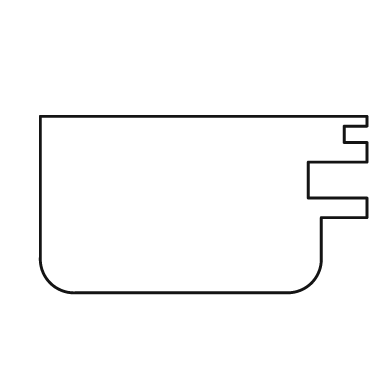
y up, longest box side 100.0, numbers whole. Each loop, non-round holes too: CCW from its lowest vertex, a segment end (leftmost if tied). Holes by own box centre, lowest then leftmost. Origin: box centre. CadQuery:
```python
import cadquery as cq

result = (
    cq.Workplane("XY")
    .moveTo(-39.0, -27.0)
    .lineTo(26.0, -27.0)
    .threePointArc((33.0, -24.0), (36.0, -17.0))
    .lineTo(36.0, -4.0)
    .lineTo(50.0, -4.0)
    .lineTo(50.0, 2.0)
    .lineTo(32.0, 2.0)
    .lineTo(32.0, 13.0)
    .lineTo(50.0, 13.0)
    .lineTo(50.0, 19.0)
    .lineTo(43.0, 19.0)
    .lineTo(43.0, 24.0)
    .lineTo(50.0, 24.0)
    .lineTo(50.0, 27.0)
    .lineTo(-50.0, 27.0)
    .lineTo(-50.0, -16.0)
    .threePointArc((-47.0, -24.0), (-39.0, -27.0))
    .close()
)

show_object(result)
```